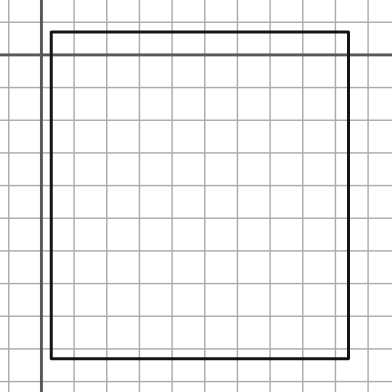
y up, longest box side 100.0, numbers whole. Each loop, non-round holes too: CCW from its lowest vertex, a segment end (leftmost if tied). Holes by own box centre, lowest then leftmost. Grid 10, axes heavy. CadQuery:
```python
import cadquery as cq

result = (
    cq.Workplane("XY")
    .moveTo(3.0, -93.0)
    .lineTo(94.0, -93.0)
    .lineTo(94.0, 7.0)
    .lineTo(3.0, 7.0)
    .close()
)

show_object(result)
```